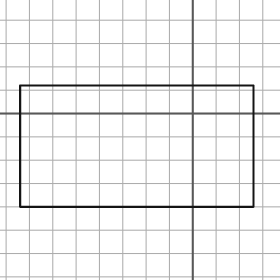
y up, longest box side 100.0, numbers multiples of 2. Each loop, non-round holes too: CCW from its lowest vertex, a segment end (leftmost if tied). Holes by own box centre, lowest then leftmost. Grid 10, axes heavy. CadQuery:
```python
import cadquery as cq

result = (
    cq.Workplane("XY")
    .moveTo(-74.0, -40.0)
    .lineTo(26.0, -40.0)
    .lineTo(26.0, 12.0)
    .lineTo(-74.0, 12.0)
    .close()
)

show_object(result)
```